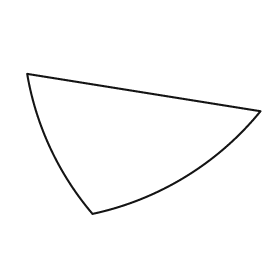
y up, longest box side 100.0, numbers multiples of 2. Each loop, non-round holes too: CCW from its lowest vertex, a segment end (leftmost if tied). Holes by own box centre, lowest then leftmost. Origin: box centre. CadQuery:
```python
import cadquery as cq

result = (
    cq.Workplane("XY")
    .moveTo(-22.0, -30.0)
    .threePointArc((18.0, -14.0), (50.0, 14.0))
    .lineTo(-50.0, 30.0)
    .threePointArc((-40.0, -2.0), (-22.0, -30.0))
    .close()
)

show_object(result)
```